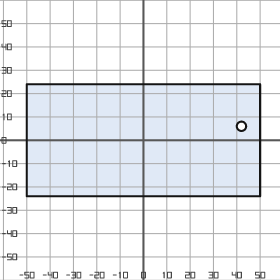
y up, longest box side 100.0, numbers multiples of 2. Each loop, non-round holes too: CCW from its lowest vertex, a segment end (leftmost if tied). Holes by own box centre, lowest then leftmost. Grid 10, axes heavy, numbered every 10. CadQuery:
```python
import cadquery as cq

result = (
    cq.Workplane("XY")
    .moveTo(-50.0, -24.0)
    .lineTo(50.0, -24.0)
    .lineTo(50.0, 24.0)
    .lineTo(-50.0, 24.0)
    .close()
    .moveTo(42.0, 6.0)
    .circle(2.0)
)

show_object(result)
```